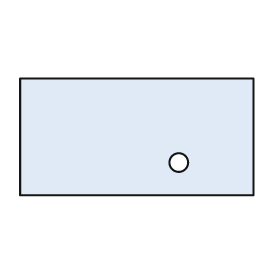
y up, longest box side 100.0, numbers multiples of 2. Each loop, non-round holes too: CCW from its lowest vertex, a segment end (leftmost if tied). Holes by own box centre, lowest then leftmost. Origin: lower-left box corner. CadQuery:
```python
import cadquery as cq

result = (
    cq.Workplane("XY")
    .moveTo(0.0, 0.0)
    .lineTo(100.0, 0.0)
    .lineTo(100.0, 50.0)
    .lineTo(0.0, 50.0)
    .close()
    .moveTo(68.0, 14.0)
    .circle(4.0)
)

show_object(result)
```